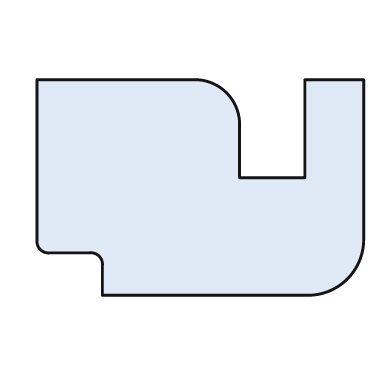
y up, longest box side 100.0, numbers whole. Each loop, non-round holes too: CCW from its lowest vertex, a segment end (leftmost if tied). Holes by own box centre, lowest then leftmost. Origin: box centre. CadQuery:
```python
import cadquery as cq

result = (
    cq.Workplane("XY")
    .moveTo(-30.0, -33.0)
    .lineTo(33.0, -33.0)
    .threePointArc((45.0, -28.0), (50.0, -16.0))
    .lineTo(50.0, 33.0)
    .lineTo(32.0, 33.0)
    .lineTo(32.0, 3.0)
    .lineTo(12.0, 3.0)
    .lineTo(12.0, 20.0)
    .threePointArc((8.0, 29.0), (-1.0, 33.0))
    .lineTo(-50.0, 33.0)
    .lineTo(-50.0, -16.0)
    .threePointArc((-49.0, -19.0), (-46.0, -20.0))
    .lineTo(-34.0, -20.0)
    .threePointArc((-31.0, -21.0), (-30.0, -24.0))
    .close()
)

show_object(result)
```